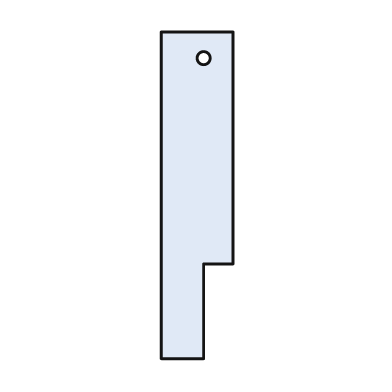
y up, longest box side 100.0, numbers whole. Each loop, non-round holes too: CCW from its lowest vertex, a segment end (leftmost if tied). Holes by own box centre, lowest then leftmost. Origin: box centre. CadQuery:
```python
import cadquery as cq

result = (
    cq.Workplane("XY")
    .moveTo(-11.0, -50.0)
    .lineTo(2.0, -50.0)
    .lineTo(2.0, -21.0)
    .lineTo(11.0, -21.0)
    .lineTo(11.0, 50.0)
    .lineTo(-11.0, 50.0)
    .close()
    .moveTo(2.0, 42.0)
    .circle(2.0)
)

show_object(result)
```